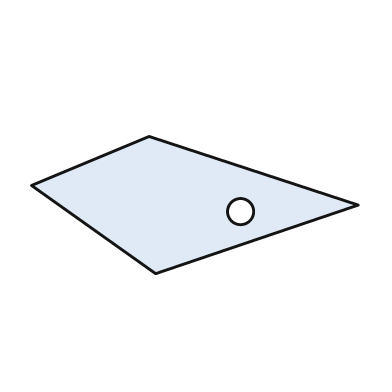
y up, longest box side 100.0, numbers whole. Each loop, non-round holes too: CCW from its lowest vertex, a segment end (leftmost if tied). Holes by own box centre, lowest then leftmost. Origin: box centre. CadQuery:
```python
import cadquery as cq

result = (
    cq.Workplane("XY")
    .moveTo(-12.0, -21.0)
    .lineTo(50.0, 0.0)
    .lineTo(-14.0, 21.0)
    .lineTo(-50.0, 6.0)
    .close()
    .moveTo(14.0, -2.0)
    .circle(4.0)
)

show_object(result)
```